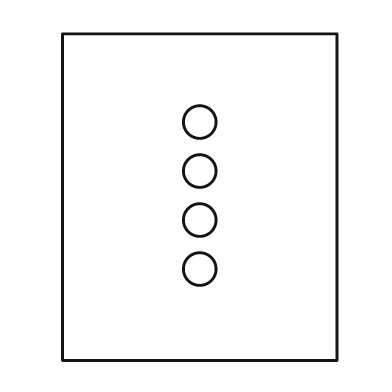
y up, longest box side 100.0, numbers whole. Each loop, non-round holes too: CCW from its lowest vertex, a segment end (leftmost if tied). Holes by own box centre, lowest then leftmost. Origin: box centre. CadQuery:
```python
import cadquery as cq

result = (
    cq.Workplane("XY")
    .moveTo(-42.0, -50.0)
    .lineTo(42.0, -50.0)
    .lineTo(42.0, 50.0)
    .lineTo(-42.0, 50.0)
    .close()
    .moveTo(0.0, -22.0)
    .circle(5.0)
    .moveTo(0.0, -7.0)
    .circle(5.0)
    .moveTo(0.0, 8.0)
    .circle(5.0)
    .moveTo(0.0, 23.0)
    .circle(5.0)
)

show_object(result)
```